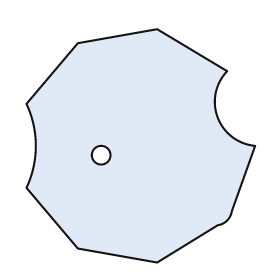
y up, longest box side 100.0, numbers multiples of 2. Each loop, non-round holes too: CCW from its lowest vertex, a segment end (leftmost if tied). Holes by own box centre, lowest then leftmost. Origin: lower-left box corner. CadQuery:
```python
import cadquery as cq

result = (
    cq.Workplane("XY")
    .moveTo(56.0, 0.0)
    .lineTo(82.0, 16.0)
    .threePointArc((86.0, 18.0), (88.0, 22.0))
    .lineTo(98.0, 50.0)
    .threePointArc((82.0, 62.0), (86.0, 82.0))
    .lineTo(56.0, 100.0)
    .lineTo(22.0, 94.0)
    .lineTo(0.0, 68.0)
    .threePointArc((4.0, 50.0), (0.0, 32.0))
    .lineTo(22.0, 6.0)
    .close()
    .moveTo(32.0, 46.0)
    .circle(4.0)
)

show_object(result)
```